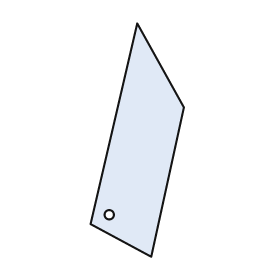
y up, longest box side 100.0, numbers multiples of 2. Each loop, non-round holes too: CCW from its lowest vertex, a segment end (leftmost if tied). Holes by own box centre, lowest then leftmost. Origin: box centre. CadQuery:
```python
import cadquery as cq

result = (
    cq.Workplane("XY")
    .moveTo(6.0, -50.0)
    .lineTo(20.0, 14.0)
    .lineTo(0.0, 50.0)
    .lineTo(-20.0, -36.0)
    .close()
    .moveTo(-12.0, -32.0)
    .circle(2.0)
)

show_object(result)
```